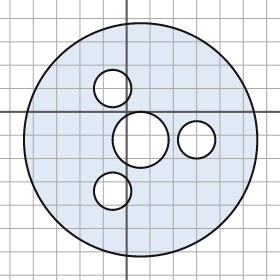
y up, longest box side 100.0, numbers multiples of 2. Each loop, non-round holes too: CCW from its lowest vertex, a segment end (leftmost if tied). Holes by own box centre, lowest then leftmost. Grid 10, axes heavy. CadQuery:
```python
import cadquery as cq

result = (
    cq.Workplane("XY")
    .moveTo(6.0, -12.0)
    .circle(50.0)
    .moveTo(-6.0, -34.0)
    .circle(8.0)
    .moveTo(6.0, -12.0)
    .circle(12.0)
    .moveTo(30.0, -12.0)
    .circle(8.0)
    .moveTo(-6.0, 10.0)
    .circle(8.0)
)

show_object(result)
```